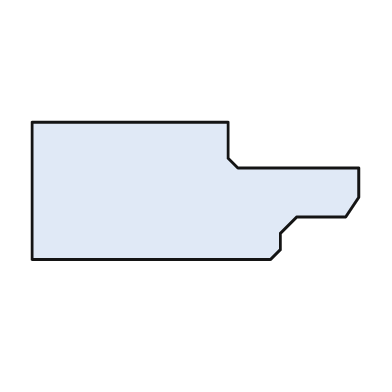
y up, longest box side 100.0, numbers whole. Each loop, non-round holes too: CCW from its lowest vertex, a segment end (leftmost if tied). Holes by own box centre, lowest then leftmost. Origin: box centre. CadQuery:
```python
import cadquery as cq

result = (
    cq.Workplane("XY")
    .moveTo(-50.0, -21.0)
    .lineTo(23.0, -21.0)
    .lineTo(26.0, -18.0)
    .lineTo(26.0, -13.0)
    .lineTo(31.0, -8.0)
    .lineTo(46.0, -8.0)
    .lineTo(50.0, -2.0)
    .lineTo(50.0, 7.0)
    .lineTo(13.0, 7.0)
    .lineTo(10.0, 10.0)
    .lineTo(10.0, 21.0)
    .lineTo(-50.0, 21.0)
    .close()
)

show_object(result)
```